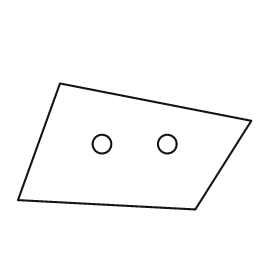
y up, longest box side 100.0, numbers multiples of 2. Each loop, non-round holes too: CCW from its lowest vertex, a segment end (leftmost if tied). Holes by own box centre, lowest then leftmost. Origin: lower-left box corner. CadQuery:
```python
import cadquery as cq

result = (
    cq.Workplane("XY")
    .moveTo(76.0, 0.0)
    .lineTo(100.0, 38.0)
    .lineTo(18.0, 54.0)
    .lineTo(0.0, 4.0)
    .close()
    .moveTo(36.0, 28.0)
    .circle(4.0)
    .moveTo(64.0, 28.0)
    .circle(4.0)
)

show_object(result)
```